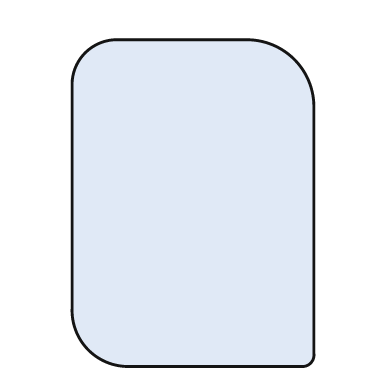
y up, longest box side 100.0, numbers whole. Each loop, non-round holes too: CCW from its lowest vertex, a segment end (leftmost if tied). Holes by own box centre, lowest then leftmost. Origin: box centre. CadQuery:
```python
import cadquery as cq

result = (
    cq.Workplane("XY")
    .moveTo(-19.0, -50.0)
    .lineTo(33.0, -50.0)
    .threePointArc((36.0, -49.0), (37.0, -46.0))
    .lineTo(37.0, 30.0)
    .threePointArc((31.0, 44.0), (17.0, 50.0))
    .lineTo(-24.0, 50.0)
    .threePointArc((-33.0, 46.0), (-37.0, 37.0))
    .lineTo(-37.0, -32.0)
    .threePointArc((-32.0, -45.0), (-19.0, -50.0))
    .close()
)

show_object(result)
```